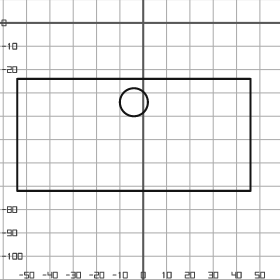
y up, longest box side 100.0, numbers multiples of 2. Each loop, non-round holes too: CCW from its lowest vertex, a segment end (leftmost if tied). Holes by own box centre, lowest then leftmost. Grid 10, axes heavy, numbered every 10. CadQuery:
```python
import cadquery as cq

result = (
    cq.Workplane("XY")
    .moveTo(-54.0, -72.0)
    .lineTo(46.0, -72.0)
    .lineTo(46.0, -24.0)
    .lineTo(-54.0, -24.0)
    .close()
    .moveTo(-4.0, -34.0)
    .circle(6.0)
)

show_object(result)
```